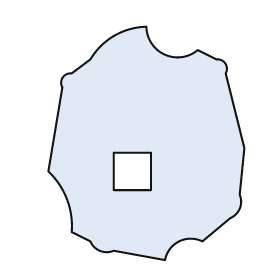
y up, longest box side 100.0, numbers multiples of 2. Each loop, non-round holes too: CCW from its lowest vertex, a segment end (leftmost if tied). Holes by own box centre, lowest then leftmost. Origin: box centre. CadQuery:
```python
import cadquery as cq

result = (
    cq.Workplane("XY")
    .moveTo(8.0, -50.0)
    .threePointArc((14.0, -42.0), (24.0, -42.0))
    .lineTo(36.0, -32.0)
    .threePointArc((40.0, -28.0), (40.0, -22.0))
    .lineTo(42.0, -2.0)
    .lineTo(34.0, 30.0)
    .threePointArc((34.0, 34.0), (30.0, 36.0))
    .lineTo(22.0, 40.0)
    .threePointArc((8.0, 38.0), (0.0, 50.0))
    .threePointArc((-14.0, 46.0), (-24.0, 36.0))
    .lineTo(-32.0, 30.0)
    .threePointArc((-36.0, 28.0), (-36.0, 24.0))
    .lineTo(-42.0, -12.0)
    .threePointArc((-34.0, -24.0), (-32.0, -38.0))
    .lineTo(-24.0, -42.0)
    .threePointArc((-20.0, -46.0), (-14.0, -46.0))
    .close()
    .moveTo(-14.0, -20.0)
    .lineTo(2.0, -20.0)
    .lineTo(2.0, -4.0)
    .lineTo(-14.0, -4.0)
    .close()
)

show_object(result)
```